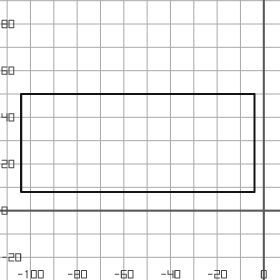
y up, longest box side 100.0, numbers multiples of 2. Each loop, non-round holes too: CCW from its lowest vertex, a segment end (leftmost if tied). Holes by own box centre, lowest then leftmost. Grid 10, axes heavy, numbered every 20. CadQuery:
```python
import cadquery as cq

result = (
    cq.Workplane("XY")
    .moveTo(-104.0, 8.0)
    .lineTo(-4.0, 8.0)
    .lineTo(-4.0, 50.0)
    .lineTo(-104.0, 50.0)
    .close()
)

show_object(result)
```